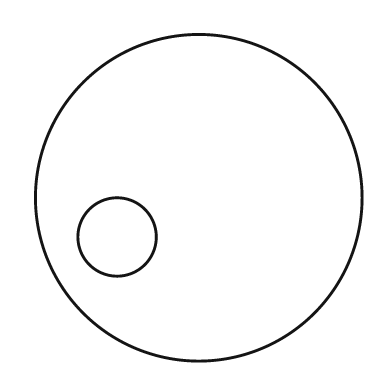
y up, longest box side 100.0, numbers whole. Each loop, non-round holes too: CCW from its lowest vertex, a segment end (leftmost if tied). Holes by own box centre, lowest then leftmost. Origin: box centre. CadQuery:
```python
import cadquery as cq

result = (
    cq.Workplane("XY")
    .moveTo(0.0, 0.0)
    .circle(50.0)
    .moveTo(-25.0, -12.0)
    .circle(12.0)
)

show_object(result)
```